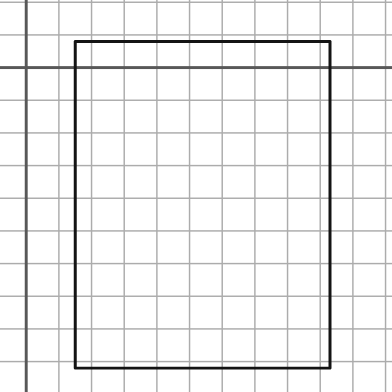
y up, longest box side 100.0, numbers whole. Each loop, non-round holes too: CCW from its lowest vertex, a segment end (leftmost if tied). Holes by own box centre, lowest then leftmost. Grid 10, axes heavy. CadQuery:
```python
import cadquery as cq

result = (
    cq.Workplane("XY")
    .moveTo(15.0, -92.0)
    .lineTo(93.0, -92.0)
    .lineTo(93.0, 8.0)
    .lineTo(15.0, 8.0)
    .close()
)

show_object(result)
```